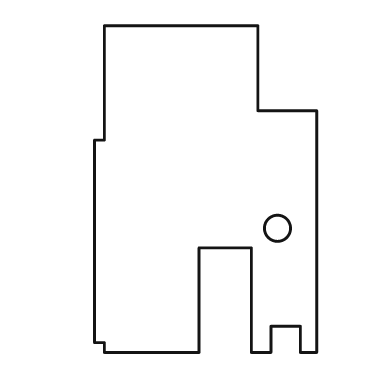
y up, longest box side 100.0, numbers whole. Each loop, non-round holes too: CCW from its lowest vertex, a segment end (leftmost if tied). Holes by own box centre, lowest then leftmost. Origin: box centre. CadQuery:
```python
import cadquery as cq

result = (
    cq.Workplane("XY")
    .moveTo(-31.0, -50.0)
    .lineTo(-2.0, -50.0)
    .lineTo(-2.0, -18.0)
    .lineTo(14.0, -18.0)
    .lineTo(14.0, -50.0)
    .lineTo(20.0, -50.0)
    .lineTo(20.0, -42.0)
    .lineTo(29.0, -42.0)
    .lineTo(29.0, -50.0)
    .lineTo(34.0, -50.0)
    .lineTo(34.0, 24.0)
    .lineTo(16.0, 24.0)
    .lineTo(16.0, 50.0)
    .lineTo(-31.0, 50.0)
    .lineTo(-31.0, 15.0)
    .lineTo(-34.0, 15.0)
    .lineTo(-34.0, -47.0)
    .lineTo(-31.0, -47.0)
    .close()
    .moveTo(22.0, -12.0)
    .circle(4.0)
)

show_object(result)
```